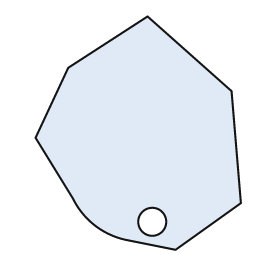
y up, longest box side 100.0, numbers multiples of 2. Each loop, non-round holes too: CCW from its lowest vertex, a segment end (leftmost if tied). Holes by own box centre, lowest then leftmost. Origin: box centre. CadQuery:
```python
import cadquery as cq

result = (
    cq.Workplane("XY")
    .moveTo(16.0, -50.0)
    .lineTo(44.0, -30.0)
    .lineTo(40.0, 18.0)
    .lineTo(4.0, 50.0)
    .lineTo(-30.0, 28.0)
    .lineTo(-44.0, -2.0)
    .lineTo(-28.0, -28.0)
    .threePointArc((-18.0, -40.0), (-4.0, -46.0))
    .close()
    .moveTo(6.0, -38.0)
    .circle(6.0)
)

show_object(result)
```